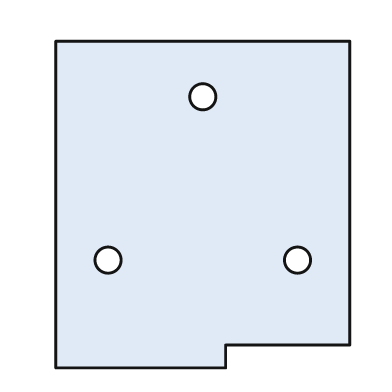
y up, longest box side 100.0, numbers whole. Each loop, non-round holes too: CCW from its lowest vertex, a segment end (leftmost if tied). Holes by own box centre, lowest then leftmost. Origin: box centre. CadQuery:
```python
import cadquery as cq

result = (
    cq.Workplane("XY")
    .moveTo(-45.0, -50.0)
    .lineTo(7.0, -50.0)
    .lineTo(7.0, -43.0)
    .lineTo(45.0, -43.0)
    .lineTo(45.0, 50.0)
    .lineTo(-45.0, 50.0)
    .close()
    .moveTo(-29.0, -17.0)
    .circle(4.0)
    .moveTo(29.0, -17.0)
    .circle(4.0)
    .moveTo(0.0, 33.0)
    .circle(4.0)
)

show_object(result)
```